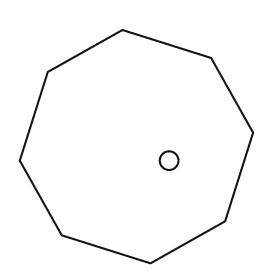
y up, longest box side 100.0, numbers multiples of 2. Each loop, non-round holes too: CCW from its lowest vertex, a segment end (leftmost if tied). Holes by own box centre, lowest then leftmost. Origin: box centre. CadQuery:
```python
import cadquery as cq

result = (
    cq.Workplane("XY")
    .moveTo(6.0, -50.0)
    .lineTo(38.0, -32.0)
    .lineTo(50.0, 6.0)
    .lineTo(32.0, 38.0)
    .lineTo(-6.0, 50.0)
    .lineTo(-38.0, 32.0)
    .lineTo(-50.0, -6.0)
    .lineTo(-32.0, -38.0)
    .close()
    .moveTo(14.0, -6.0)
    .circle(4.0)
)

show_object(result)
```